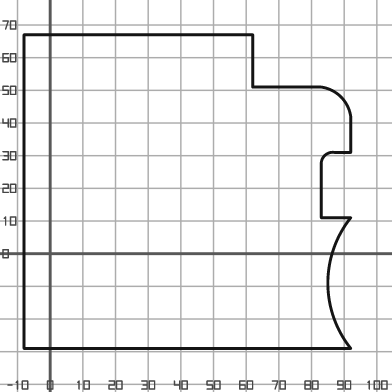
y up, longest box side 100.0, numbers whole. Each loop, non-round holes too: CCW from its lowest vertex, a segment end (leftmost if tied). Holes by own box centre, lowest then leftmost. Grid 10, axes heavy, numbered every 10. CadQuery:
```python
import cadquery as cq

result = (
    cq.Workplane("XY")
    .moveTo(-8.0, -29.0)
    .lineTo(92.0, -29.0)
    .threePointArc((85.0, -9.0), (92.0, 11.0))
    .lineTo(83.0, 11.0)
    .lineTo(83.0, 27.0)
    .threePointArc((84.0, 30.0), (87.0, 31.0))
    .lineTo(92.0, 31.0)
    .lineTo(92.0, 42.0)
    .threePointArc((89.0, 48.0), (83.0, 51.0))
    .lineTo(62.0, 51.0)
    .lineTo(62.0, 67.0)
    .lineTo(-8.0, 67.0)
    .close()
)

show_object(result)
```